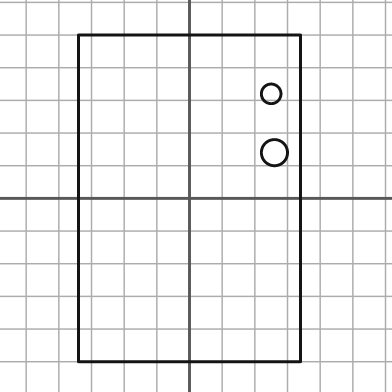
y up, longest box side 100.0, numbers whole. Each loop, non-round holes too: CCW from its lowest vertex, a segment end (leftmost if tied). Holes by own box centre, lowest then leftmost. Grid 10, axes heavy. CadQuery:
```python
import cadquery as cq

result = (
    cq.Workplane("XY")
    .moveTo(-34.0, -50.0)
    .lineTo(34.0, -50.0)
    .lineTo(34.0, 50.0)
    .lineTo(-34.0, 50.0)
    .close()
    .moveTo(26.0, 14.0)
    .circle(4.0)
    .moveTo(25.0, 32.0)
    .circle(3.0)
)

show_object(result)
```